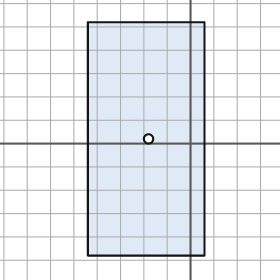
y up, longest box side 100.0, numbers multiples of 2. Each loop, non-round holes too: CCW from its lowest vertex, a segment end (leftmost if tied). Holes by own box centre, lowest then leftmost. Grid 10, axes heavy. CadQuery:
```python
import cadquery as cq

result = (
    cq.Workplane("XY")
    .moveTo(-44.0, -48.0)
    .lineTo(6.0, -48.0)
    .lineTo(6.0, 52.0)
    .lineTo(-44.0, 52.0)
    .close()
    .moveTo(-18.0, 2.0)
    .circle(2.0)
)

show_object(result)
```